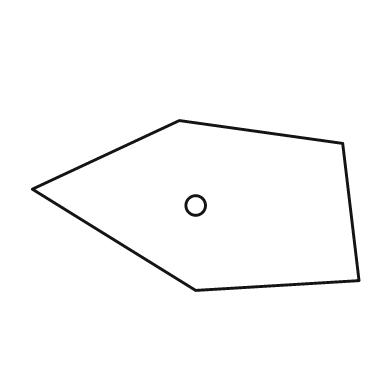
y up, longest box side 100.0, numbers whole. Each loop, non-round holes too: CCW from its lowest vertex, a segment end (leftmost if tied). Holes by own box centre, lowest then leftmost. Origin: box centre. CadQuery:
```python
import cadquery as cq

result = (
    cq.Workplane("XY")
    .moveTo(0.0, -26.0)
    .lineTo(50.0, -23.0)
    .lineTo(45.0, 19.0)
    .lineTo(-5.0, 26.0)
    .lineTo(-50.0, 5.0)
    .close()
    .moveTo(0.0, 0.0)
    .circle(3.0)
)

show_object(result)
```